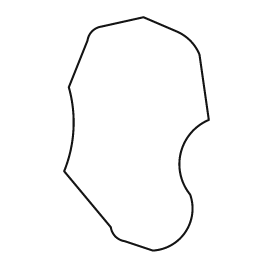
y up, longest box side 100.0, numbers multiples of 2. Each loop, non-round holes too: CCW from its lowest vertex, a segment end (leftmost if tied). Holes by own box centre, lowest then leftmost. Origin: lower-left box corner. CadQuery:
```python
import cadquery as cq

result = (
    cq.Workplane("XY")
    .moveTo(38.0, 0.0)
    .threePointArc((52.0, 8.0), (54.0, 24.0))
    .threePointArc((50.0, 42.0), (62.0, 56.0))
    .lineTo(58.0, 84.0)
    .threePointArc((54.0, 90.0), (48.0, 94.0))
    .lineTo(34.0, 100.0)
    .lineTo(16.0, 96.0)
    .threePointArc((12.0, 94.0), (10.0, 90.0))
    .lineTo(2.0, 70.0)
    .threePointArc((4.0, 52.0), (0.0, 34.0))
    .lineTo(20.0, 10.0)
    .threePointArc((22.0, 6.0), (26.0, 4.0))
    .close()
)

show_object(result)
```